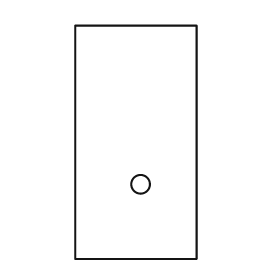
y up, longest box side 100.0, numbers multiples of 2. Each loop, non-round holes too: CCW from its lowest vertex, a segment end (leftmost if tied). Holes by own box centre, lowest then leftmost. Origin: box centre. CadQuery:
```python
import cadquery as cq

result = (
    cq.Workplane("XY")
    .moveTo(-26.0, -50.0)
    .lineTo(26.0, -50.0)
    .lineTo(26.0, 50.0)
    .lineTo(-26.0, 50.0)
    .close()
    .moveTo(2.0, -18.0)
    .circle(4.0)
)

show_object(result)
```